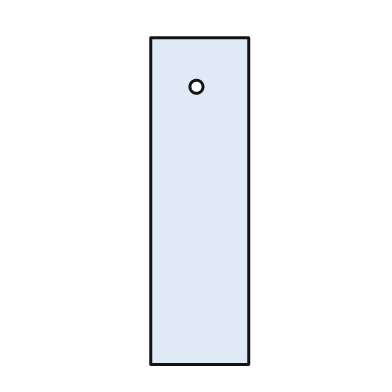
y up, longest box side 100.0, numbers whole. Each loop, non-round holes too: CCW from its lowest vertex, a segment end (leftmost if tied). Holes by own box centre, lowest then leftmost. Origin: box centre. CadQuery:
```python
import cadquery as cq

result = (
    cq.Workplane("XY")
    .moveTo(-15.0, -50.0)
    .lineTo(15.0, -50.0)
    .lineTo(15.0, 50.0)
    .lineTo(-15.0, 50.0)
    .close()
    .moveTo(-1.0, 35.0)
    .circle(2.0)
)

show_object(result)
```